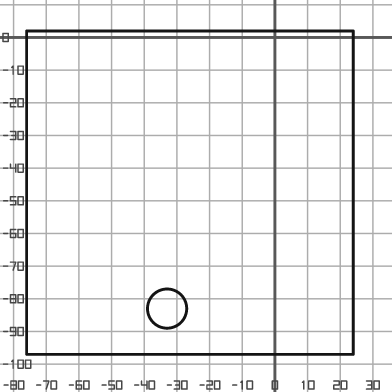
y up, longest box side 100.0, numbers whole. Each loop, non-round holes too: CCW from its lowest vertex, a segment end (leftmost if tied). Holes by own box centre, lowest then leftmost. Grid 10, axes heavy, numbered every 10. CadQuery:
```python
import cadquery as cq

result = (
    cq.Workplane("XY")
    .moveTo(-76.0, -97.0)
    .lineTo(24.0, -97.0)
    .lineTo(24.0, 2.0)
    .lineTo(-76.0, 2.0)
    .close()
    .moveTo(-33.0, -83.0)
    .circle(6.0)
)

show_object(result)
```